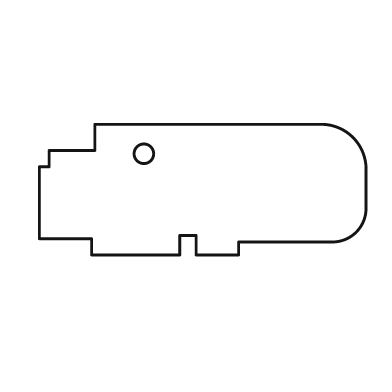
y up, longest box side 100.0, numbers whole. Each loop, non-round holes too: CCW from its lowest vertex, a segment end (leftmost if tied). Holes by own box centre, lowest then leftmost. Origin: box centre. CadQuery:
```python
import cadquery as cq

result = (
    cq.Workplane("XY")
    .moveTo(-34.0, -20.0)
    .lineTo(-7.0, -20.0)
    .lineTo(-7.0, -14.0)
    .lineTo(-2.0, -14.0)
    .lineTo(-2.0, -20.0)
    .lineTo(11.0, -20.0)
    .lineTo(11.0, -16.0)
    .lineTo(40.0, -16.0)
    .threePointArc((47.0, -13.0), (50.0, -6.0))
    .lineTo(50.0, 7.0)
    .threePointArc((46.0, 16.0), (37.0, 20.0))
    .lineTo(-33.0, 20.0)
    .lineTo(-33.0, 12.0)
    .lineTo(-47.0, 12.0)
    .lineTo(-47.0, 7.0)
    .lineTo(-50.0, 7.0)
    .lineTo(-50.0, -15.0)
    .lineTo(-34.0, -15.0)
    .close()
    .moveTo(-18.0, 11.0)
    .circle(3.0)
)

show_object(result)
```